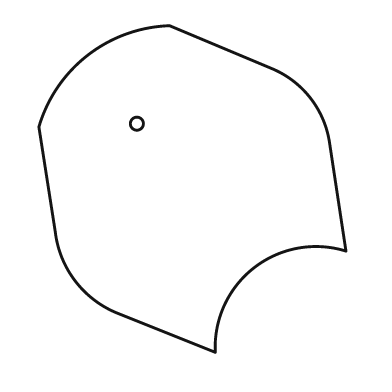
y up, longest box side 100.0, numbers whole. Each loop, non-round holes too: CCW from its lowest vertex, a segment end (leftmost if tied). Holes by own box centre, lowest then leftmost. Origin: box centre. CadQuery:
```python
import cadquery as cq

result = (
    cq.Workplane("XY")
    .moveTo(7.0, -50.0)
    .threePointArc((19.0, -24.0), (47.0, -19.0))
    .lineTo(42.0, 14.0)
    .threePointArc((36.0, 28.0), (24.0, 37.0))
    .lineTo(-7.0, 50.0)
    .threePointArc((-32.0, 41.0), (-47.0, 19.0))
    .lineTo(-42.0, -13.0)
    .threePointArc((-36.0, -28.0), (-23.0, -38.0))
    .close()
    .moveTo(-17.0, 20.0)
    .circle(2.0)
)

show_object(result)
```